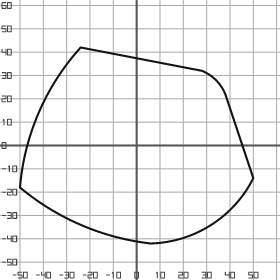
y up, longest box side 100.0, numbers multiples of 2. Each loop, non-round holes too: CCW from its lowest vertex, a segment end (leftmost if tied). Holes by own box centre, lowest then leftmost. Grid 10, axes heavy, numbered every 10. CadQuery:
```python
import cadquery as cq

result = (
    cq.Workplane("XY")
    .moveTo(6.0, -42.0)
    .threePointArc((32.0, -34.0), (50.0, -14.0))
    .lineTo(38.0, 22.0)
    .threePointArc((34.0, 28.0), (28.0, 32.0))
    .lineTo(-24.0, 42.0)
    .threePointArc((-42.0, 14.0), (-50.0, -18.0))
    .threePointArc((-24.0, -34.0), (6.0, -42.0))
    .close()
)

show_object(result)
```